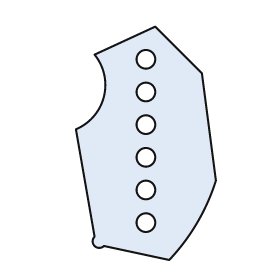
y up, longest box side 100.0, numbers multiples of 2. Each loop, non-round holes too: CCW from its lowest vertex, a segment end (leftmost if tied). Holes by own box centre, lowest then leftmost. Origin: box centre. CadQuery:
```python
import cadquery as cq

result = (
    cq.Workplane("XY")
    .moveTo(10.0, -50.0)
    .threePointArc((22.0, -34.0), (30.0, -16.0))
    .lineTo(24.0, 30.0)
    .lineTo(4.0, 50.0)
    .lineTo(-22.0, 38.0)
    .threePointArc((-18.0, 20.0), (-30.0, 6.0))
    .lineTo(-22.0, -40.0)
    .threePointArc((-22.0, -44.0), (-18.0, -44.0))
    .close()
    .moveTo(0.0, -34.0)
    .circle(4.0)
    .moveTo(0.0, -20.0)
    .circle(4.0)
    .moveTo(0.0, -6.0)
    .circle(4.0)
    .moveTo(0.0, 8.0)
    .circle(4.0)
    .moveTo(0.0, 22.0)
    .circle(4.0)
    .moveTo(0.0, 36.0)
    .circle(4.0)
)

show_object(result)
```